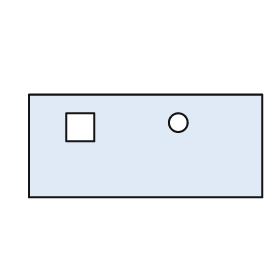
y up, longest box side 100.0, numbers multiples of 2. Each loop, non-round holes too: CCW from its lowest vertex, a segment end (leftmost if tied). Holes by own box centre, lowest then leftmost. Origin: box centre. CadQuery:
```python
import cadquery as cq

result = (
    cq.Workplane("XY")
    .moveTo(-50.0, -22.0)
    .lineTo(50.0, -22.0)
    .lineTo(50.0, 22.0)
    .lineTo(-50.0, 22.0)
    .close()
    .moveTo(-34.0, 2.0)
    .lineTo(-22.0, 2.0)
    .lineTo(-22.0, 14.0)
    .lineTo(-34.0, 14.0)
    .close()
    .moveTo(14.0, 10.0)
    .circle(4.0)
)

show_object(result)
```